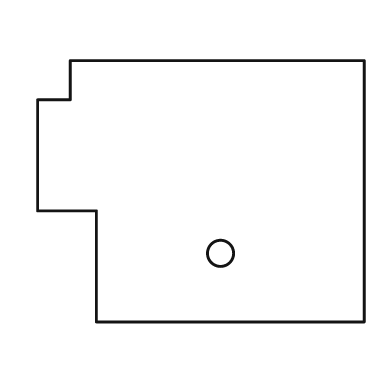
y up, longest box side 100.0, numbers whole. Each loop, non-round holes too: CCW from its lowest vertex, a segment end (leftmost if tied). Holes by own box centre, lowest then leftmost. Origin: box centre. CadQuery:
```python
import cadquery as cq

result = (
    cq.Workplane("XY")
    .moveTo(-32.0, -40.0)
    .lineTo(50.0, -40.0)
    .lineTo(50.0, 40.0)
    .lineTo(-40.0, 40.0)
    .lineTo(-40.0, 28.0)
    .lineTo(-50.0, 28.0)
    .lineTo(-50.0, -6.0)
    .lineTo(-32.0, -6.0)
    .close()
    .moveTo(6.0, -19.0)
    .circle(4.0)
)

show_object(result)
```